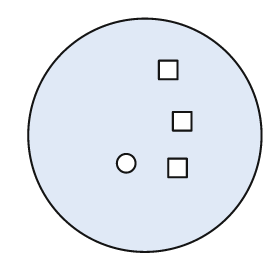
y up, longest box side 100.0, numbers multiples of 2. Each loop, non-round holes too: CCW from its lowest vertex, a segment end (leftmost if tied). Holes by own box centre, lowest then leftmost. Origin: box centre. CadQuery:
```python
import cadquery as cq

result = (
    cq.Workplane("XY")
    .moveTo(0.0, 0.0)
    .circle(50.0)
    .moveTo(10.0, -18.0)
    .lineTo(18.0, -18.0)
    .lineTo(18.0, -10.0)
    .lineTo(10.0, -10.0)
    .close()
    .moveTo(-8.0, -12.0)
    .circle(4.0)
    .moveTo(12.0, 2.0)
    .lineTo(20.0, 2.0)
    .lineTo(20.0, 10.0)
    .lineTo(12.0, 10.0)
    .close()
    .moveTo(6.0, 24.0)
    .lineTo(14.0, 24.0)
    .lineTo(14.0, 32.0)
    .lineTo(6.0, 32.0)
    .close()
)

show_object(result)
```